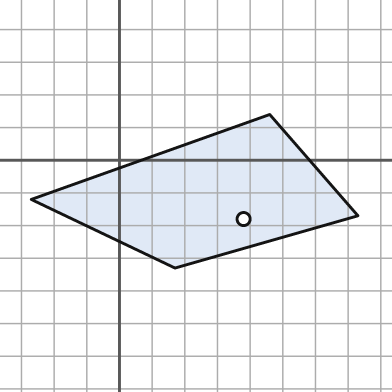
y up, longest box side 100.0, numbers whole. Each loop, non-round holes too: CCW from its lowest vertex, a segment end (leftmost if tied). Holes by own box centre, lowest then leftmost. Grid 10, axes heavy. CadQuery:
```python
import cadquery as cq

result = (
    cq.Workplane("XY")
    .moveTo(17.0, -33.0)
    .lineTo(73.0, -17.0)
    .lineTo(46.0, 14.0)
    .lineTo(-27.0, -12.0)
    .close()
    .moveTo(38.0, -18.0)
    .circle(2.0)
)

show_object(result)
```